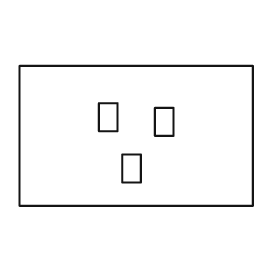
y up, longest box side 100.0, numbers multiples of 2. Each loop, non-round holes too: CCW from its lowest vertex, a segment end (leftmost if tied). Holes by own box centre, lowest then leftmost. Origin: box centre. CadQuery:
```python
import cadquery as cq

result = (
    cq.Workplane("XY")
    .moveTo(-50.0, -30.0)
    .lineTo(50.0, -30.0)
    .lineTo(50.0, 30.0)
    .lineTo(-50.0, 30.0)
    .close()
    .moveTo(-6.0, -20.0)
    .lineTo(2.0, -20.0)
    .lineTo(2.0, -8.0)
    .lineTo(-6.0, -8.0)
    .close()
    .moveTo(8.0, 0.0)
    .lineTo(16.0, 0.0)
    .lineTo(16.0, 12.0)
    .lineTo(8.0, 12.0)
    .close()
    .moveTo(-16.0, 2.0)
    .lineTo(-8.0, 2.0)
    .lineTo(-8.0, 14.0)
    .lineTo(-16.0, 14.0)
    .close()
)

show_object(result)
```